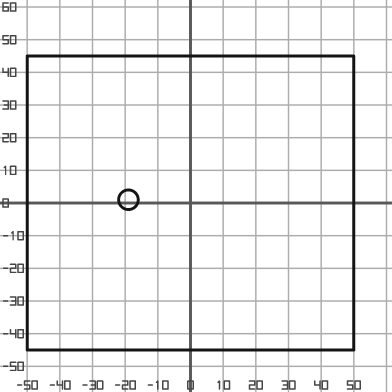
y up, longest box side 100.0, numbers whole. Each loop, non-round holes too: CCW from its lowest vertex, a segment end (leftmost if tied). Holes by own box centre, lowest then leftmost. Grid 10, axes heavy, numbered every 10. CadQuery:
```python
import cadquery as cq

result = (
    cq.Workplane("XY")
    .moveTo(-50.0, -45.0)
    .lineTo(50.0, -45.0)
    .lineTo(50.0, 45.0)
    .lineTo(-50.0, 45.0)
    .close()
    .moveTo(-19.0, 1.0)
    .circle(3.0)
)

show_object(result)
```